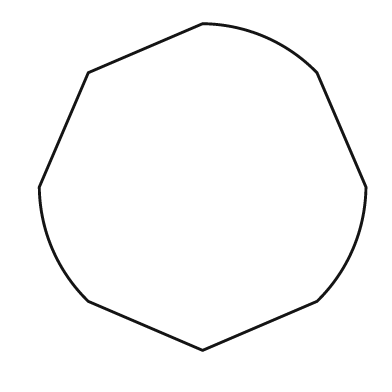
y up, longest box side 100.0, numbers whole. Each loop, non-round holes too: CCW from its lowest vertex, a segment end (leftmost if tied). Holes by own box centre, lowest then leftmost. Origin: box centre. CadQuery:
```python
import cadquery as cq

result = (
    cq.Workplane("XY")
    .moveTo(0.0, -50.0)
    .lineTo(35.0, -35.0)
    .threePointArc((46.0, -19.0), (50.0, 0.0))
    .lineTo(35.0, 35.0)
    .threePointArc((19.0, 46.0), (0.0, 50.0))
    .lineTo(-35.0, 35.0)
    .lineTo(-50.0, 0.0)
    .threePointArc((-46.0, -19.0), (-35.0, -35.0))
    .close()
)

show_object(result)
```